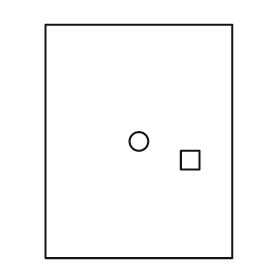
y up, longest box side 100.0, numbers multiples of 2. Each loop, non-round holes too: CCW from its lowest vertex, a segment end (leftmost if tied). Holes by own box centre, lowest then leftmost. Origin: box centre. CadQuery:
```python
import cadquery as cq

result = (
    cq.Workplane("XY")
    .moveTo(-40.0, -50.0)
    .lineTo(40.0, -50.0)
    .lineTo(40.0, 50.0)
    .lineTo(-40.0, 50.0)
    .close()
    .moveTo(18.0, -12.0)
    .lineTo(26.0, -12.0)
    .lineTo(26.0, -4.0)
    .lineTo(18.0, -4.0)
    .close()
    .moveTo(0.0, 0.0)
    .circle(4.0)
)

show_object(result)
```